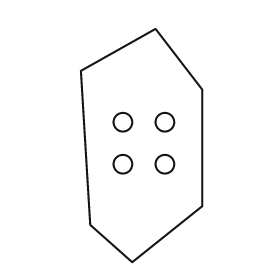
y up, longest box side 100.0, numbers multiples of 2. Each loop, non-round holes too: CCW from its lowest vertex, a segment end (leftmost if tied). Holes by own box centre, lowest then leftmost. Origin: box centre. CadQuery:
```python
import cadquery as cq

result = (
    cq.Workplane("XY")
    .moveTo(-4.0, -50.0)
    .lineTo(26.0, -26.0)
    .lineTo(26.0, 24.0)
    .lineTo(6.0, 50.0)
    .lineTo(-26.0, 32.0)
    .lineTo(-22.0, -34.0)
    .close()
    .moveTo(-8.0, -8.0)
    .circle(4.0)
    .moveTo(10.0, -8.0)
    .circle(4.0)
    .moveTo(-8.0, 10.0)
    .circle(4.0)
    .moveTo(10.0, 10.0)
    .circle(4.0)
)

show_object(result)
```